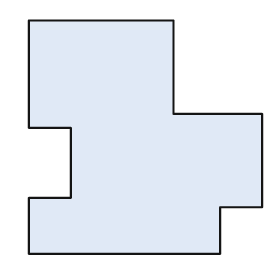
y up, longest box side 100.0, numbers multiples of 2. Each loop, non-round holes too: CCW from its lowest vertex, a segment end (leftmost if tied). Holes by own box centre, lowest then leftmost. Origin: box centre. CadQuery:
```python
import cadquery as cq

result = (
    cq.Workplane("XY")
    .moveTo(-50.0, -50.0)
    .lineTo(32.0, -50.0)
    .lineTo(32.0, -30.0)
    .lineTo(50.0, -30.0)
    .lineTo(50.0, 10.0)
    .lineTo(12.0, 10.0)
    .lineTo(12.0, 50.0)
    .lineTo(-50.0, 50.0)
    .lineTo(-50.0, 4.0)
    .lineTo(-32.0, 4.0)
    .lineTo(-32.0, -26.0)
    .lineTo(-50.0, -26.0)
    .close()
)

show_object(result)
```